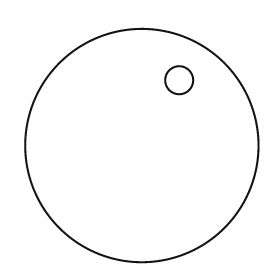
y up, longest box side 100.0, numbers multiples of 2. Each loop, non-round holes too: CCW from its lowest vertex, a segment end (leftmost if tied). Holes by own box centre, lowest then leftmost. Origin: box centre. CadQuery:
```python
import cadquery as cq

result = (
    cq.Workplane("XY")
    .moveTo(0.0, 0.0)
    .circle(50.0)
    .moveTo(16.0, 28.0)
    .circle(6.0)
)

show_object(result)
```